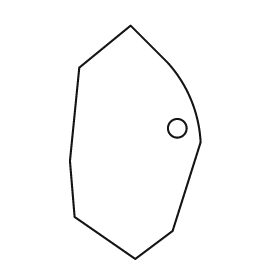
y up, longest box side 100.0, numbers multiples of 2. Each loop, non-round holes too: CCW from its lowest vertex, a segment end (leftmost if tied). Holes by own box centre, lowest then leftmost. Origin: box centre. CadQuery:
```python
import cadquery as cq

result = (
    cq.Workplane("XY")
    .moveTo(0.0, -50.0)
    .lineTo(16.0, -38.0)
    .lineTo(28.0, 0.0)
    .threePointArc((24.0, 18.0), (14.0, 34.0))
    .lineTo(-2.0, 50.0)
    .lineTo(-24.0, 32.0)
    .lineTo(-28.0, -8.0)
    .lineTo(-26.0, -32.0)
    .close()
    .moveTo(18.0, 6.0)
    .circle(4.0)
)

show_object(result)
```